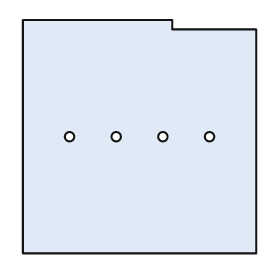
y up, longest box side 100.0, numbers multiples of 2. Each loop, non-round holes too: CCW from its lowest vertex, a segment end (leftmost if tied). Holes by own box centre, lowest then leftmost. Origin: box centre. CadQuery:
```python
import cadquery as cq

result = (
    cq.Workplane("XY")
    .moveTo(-50.0, -50.0)
    .lineTo(50.0, -50.0)
    .lineTo(50.0, 46.0)
    .lineTo(14.0, 46.0)
    .lineTo(14.0, 50.0)
    .lineTo(-50.0, 50.0)
    .close()
    .moveTo(-30.0, 0.0)
    .circle(2.0)
    .moveTo(-10.0, 0.0)
    .circle(2.0)
    .moveTo(10.0, 0.0)
    .circle(2.0)
    .moveTo(30.0, 0.0)
    .circle(2.0)
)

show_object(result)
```